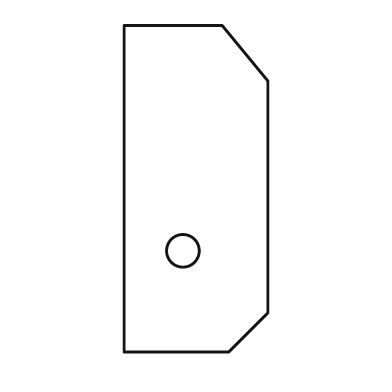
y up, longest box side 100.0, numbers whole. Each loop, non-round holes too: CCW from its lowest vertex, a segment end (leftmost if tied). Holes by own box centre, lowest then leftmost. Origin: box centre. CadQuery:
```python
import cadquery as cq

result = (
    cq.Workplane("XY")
    .moveTo(-22.0, -50.0)
    .lineTo(10.0, -50.0)
    .lineTo(22.0, -38.0)
    .lineTo(22.0, 33.0)
    .lineTo(8.0, 50.0)
    .lineTo(-22.0, 50.0)
    .close()
    .moveTo(-4.0, -19.0)
    .circle(5.0)
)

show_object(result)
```